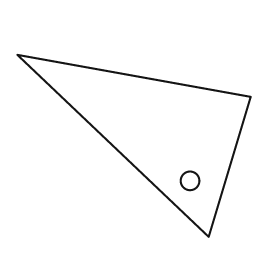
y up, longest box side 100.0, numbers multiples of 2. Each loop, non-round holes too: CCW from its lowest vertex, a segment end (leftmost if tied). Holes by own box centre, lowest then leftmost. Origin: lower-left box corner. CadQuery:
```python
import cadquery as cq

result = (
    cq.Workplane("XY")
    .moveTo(82.0, 0.0)
    .lineTo(100.0, 60.0)
    .lineTo(0.0, 78.0)
    .close()
    .moveTo(74.0, 24.0)
    .circle(4.0)
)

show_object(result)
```